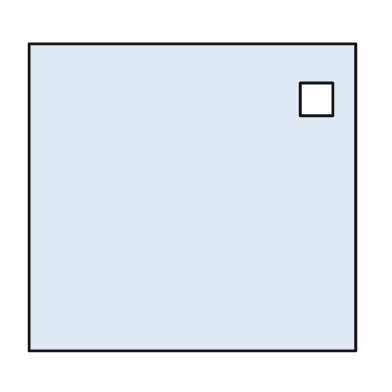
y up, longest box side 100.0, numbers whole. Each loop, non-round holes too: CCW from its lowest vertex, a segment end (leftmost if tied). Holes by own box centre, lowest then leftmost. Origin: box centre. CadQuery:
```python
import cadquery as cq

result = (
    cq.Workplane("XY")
    .moveTo(-50.0, -47.0)
    .lineTo(50.0, -47.0)
    .lineTo(50.0, 47.0)
    .lineTo(-50.0, 47.0)
    .close()
    .moveTo(33.0, 25.0)
    .lineTo(43.0, 25.0)
    .lineTo(43.0, 35.0)
    .lineTo(33.0, 35.0)
    .close()
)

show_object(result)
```